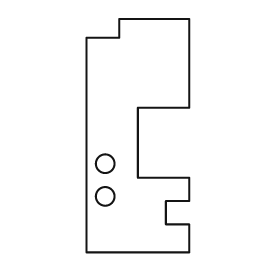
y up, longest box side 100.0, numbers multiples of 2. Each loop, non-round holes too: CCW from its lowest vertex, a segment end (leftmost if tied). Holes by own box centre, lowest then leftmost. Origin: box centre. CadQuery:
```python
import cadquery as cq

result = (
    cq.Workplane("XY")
    .moveTo(-22.0, -50.0)
    .lineTo(22.0, -50.0)
    .lineTo(22.0, -38.0)
    .lineTo(12.0, -38.0)
    .lineTo(12.0, -28.0)
    .lineTo(22.0, -28.0)
    .lineTo(22.0, -18.0)
    .lineTo(0.0, -18.0)
    .lineTo(0.0, 12.0)
    .lineTo(22.0, 12.0)
    .lineTo(22.0, 50.0)
    .lineTo(-8.0, 50.0)
    .lineTo(-8.0, 42.0)
    .lineTo(-22.0, 42.0)
    .close()
    .moveTo(-14.0, -26.0)
    .circle(4.0)
    .moveTo(-14.0, -12.0)
    .circle(4.0)
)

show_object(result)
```